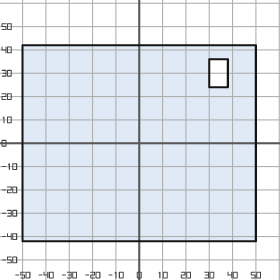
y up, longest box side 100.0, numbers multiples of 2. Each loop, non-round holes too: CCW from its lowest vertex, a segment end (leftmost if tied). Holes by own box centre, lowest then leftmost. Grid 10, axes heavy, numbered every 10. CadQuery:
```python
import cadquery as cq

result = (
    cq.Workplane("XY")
    .moveTo(-50.0, -42.0)
    .lineTo(50.0, -42.0)
    .lineTo(50.0, 42.0)
    .lineTo(-50.0, 42.0)
    .close()
    .moveTo(30.0, 24.0)
    .lineTo(38.0, 24.0)
    .lineTo(38.0, 36.0)
    .lineTo(30.0, 36.0)
    .close()
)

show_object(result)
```